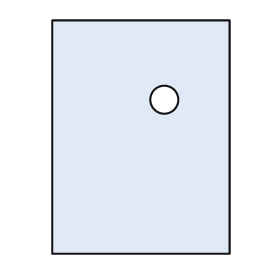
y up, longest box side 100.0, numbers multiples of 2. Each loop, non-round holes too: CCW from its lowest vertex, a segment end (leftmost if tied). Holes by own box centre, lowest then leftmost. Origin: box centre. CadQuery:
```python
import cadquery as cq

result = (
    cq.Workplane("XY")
    .moveTo(-38.0, -50.0)
    .lineTo(38.0, -50.0)
    .lineTo(38.0, 50.0)
    .lineTo(-38.0, 50.0)
    .close()
    .moveTo(10.0, 16.0)
    .circle(6.0)
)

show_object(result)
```